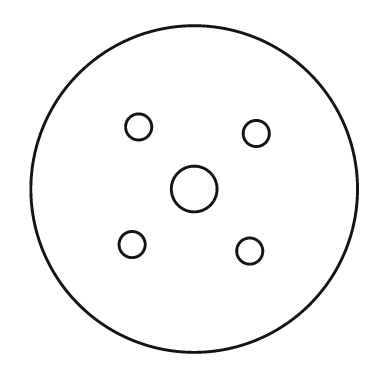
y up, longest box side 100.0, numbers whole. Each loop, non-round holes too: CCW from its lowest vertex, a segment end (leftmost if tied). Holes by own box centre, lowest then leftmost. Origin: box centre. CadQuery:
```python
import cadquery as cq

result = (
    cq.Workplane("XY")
    .moveTo(0.0, 0.0)
    .circle(50.0)
    .moveTo(17.0, -19.0)
    .circle(4.0)
    .moveTo(-19.0, -17.0)
    .circle(4.0)
    .moveTo(0.0, 0.0)
    .circle(7.0)
    .moveTo(19.0, 17.0)
    .circle(4.0)
    .moveTo(-17.0, 19.0)
    .circle(4.0)
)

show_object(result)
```